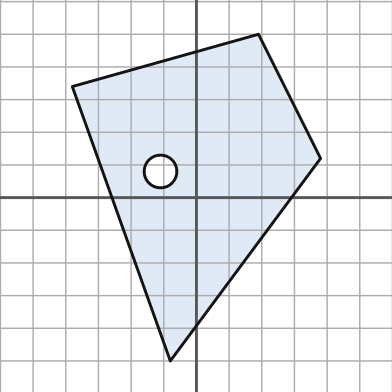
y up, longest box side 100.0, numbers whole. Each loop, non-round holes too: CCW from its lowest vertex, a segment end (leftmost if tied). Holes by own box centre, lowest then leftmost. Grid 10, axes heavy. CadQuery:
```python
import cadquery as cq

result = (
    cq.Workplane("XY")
    .moveTo(-8.0, -50.0)
    .lineTo(38.0, 12.0)
    .lineTo(19.0, 50.0)
    .lineTo(-38.0, 34.0)
    .close()
    .moveTo(-11.0, 8.0)
    .circle(5.0)
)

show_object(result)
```